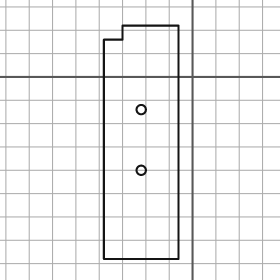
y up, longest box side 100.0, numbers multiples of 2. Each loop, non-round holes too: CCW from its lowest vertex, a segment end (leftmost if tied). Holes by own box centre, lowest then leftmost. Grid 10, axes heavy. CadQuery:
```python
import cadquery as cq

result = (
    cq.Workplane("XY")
    .moveTo(-38.0, -78.0)
    .lineTo(-6.0, -78.0)
    .lineTo(-6.0, 22.0)
    .lineTo(-30.0, 22.0)
    .lineTo(-30.0, 16.0)
    .lineTo(-38.0, 16.0)
    .close()
    .moveTo(-22.0, -40.0)
    .circle(2.0)
    .moveTo(-22.0, -14.0)
    .circle(2.0)
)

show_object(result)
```